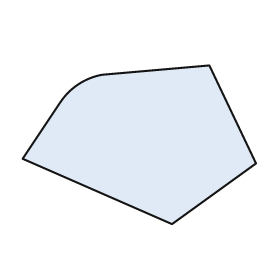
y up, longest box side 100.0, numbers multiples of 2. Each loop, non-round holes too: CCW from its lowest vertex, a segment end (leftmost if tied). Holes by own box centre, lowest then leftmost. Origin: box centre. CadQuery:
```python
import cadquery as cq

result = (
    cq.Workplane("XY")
    .moveTo(14.0, -34.0)
    .lineTo(50.0, -8.0)
    .lineTo(30.0, 34.0)
    .lineTo(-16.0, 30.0)
    .threePointArc((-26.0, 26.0), (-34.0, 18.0))
    .lineTo(-50.0, -6.0)
    .close()
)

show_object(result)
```